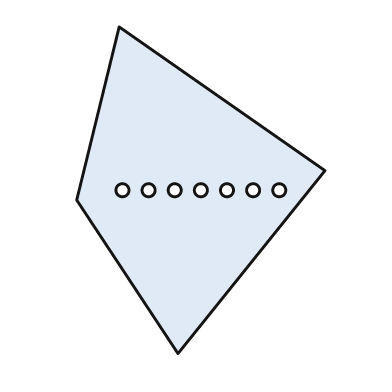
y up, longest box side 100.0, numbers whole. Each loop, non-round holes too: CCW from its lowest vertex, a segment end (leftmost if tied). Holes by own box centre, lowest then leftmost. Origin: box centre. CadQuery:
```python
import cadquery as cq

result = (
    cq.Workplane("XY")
    .moveTo(-7.0, -50.0)
    .lineTo(38.0, 6.0)
    .lineTo(-25.0, 50.0)
    .lineTo(-38.0, -3.0)
    .close()
    .moveTo(-24.0, 0.0)
    .circle(2.0)
    .moveTo(-16.0, 0.0)
    .circle(2.0)
    .moveTo(-8.0, 0.0)
    .circle(2.0)
    .moveTo(0.0, 0.0)
    .circle(2.0)
    .moveTo(8.0, 0.0)
    .circle(2.0)
    .moveTo(16.0, 0.0)
    .circle(2.0)
    .moveTo(24.0, 0.0)
    .circle(2.0)
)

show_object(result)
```